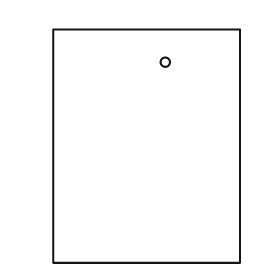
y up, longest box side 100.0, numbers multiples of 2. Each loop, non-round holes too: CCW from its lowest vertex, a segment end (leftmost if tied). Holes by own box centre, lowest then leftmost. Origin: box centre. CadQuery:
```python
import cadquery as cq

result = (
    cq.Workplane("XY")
    .moveTo(-40.0, -50.0)
    .lineTo(40.0, -50.0)
    .lineTo(40.0, 50.0)
    .lineTo(-40.0, 50.0)
    .close()
    .moveTo(8.0, 36.0)
    .circle(2.0)
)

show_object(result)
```